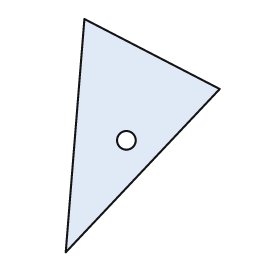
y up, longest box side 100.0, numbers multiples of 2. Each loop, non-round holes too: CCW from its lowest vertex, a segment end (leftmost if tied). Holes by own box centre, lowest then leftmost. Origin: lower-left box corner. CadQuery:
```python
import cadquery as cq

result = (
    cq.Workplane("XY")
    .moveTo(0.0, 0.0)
    .lineTo(66.0, 70.0)
    .lineTo(8.0, 100.0)
    .close()
    .moveTo(26.0, 48.0)
    .circle(4.0)
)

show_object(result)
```